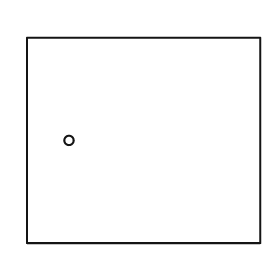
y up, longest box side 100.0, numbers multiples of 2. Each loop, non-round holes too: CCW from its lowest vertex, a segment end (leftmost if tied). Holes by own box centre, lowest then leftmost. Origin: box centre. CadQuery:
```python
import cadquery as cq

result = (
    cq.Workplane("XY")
    .moveTo(-50.0, -44.0)
    .lineTo(50.0, -44.0)
    .lineTo(50.0, 44.0)
    .lineTo(-50.0, 44.0)
    .close()
    .moveTo(-32.0, 0.0)
    .circle(2.0)
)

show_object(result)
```